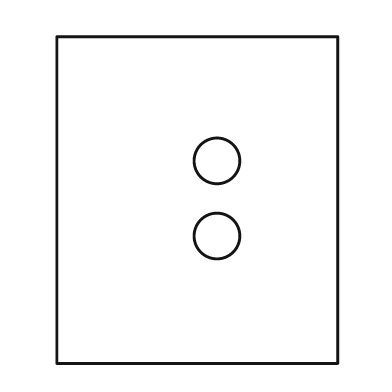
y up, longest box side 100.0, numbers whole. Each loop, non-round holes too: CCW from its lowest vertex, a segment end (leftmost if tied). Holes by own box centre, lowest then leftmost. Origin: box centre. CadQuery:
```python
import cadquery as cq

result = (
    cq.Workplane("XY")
    .moveTo(-43.0, -50.0)
    .lineTo(43.0, -50.0)
    .lineTo(43.0, 50.0)
    .lineTo(-43.0, 50.0)
    .close()
    .moveTo(6.0, -11.0)
    .circle(7.0)
    .moveTo(6.0, 12.0)
    .circle(7.0)
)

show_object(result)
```